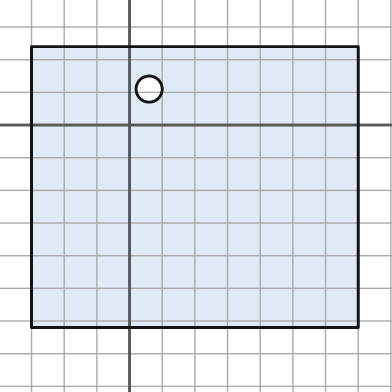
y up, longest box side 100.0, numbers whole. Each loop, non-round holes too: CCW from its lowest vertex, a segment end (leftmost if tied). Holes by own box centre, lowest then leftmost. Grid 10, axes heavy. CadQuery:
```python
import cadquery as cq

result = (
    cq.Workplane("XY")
    .moveTo(-30.0, -62.0)
    .lineTo(70.0, -62.0)
    .lineTo(70.0, 24.0)
    .lineTo(-30.0, 24.0)
    .close()
    .moveTo(6.0, 11.0)
    .circle(4.0)
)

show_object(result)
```